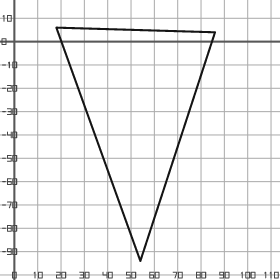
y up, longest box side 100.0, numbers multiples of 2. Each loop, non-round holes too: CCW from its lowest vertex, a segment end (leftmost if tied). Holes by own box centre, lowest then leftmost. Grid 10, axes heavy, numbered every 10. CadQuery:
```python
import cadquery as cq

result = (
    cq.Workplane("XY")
    .moveTo(54.0, -94.0)
    .lineTo(86.0, 4.0)
    .lineTo(18.0, 6.0)
    .close()
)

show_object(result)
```